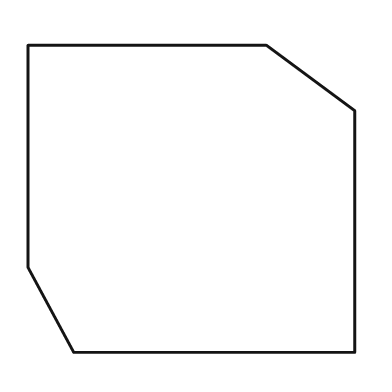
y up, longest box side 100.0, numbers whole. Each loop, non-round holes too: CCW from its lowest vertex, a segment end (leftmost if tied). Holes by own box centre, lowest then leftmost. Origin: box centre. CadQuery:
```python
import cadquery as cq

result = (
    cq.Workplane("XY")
    .moveTo(-36.0, -47.0)
    .lineTo(50.0, -47.0)
    .lineTo(50.0, 27.0)
    .lineTo(23.0, 47.0)
    .lineTo(-50.0, 47.0)
    .lineTo(-50.0, -21.0)
    .close()
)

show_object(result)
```